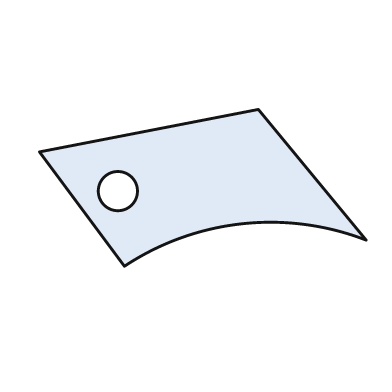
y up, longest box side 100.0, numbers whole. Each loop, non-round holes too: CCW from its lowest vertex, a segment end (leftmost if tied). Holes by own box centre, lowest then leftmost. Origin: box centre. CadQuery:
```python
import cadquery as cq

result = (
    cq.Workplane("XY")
    .moveTo(-24.0, -24.0)
    .threePointArc((12.0, -11.0), (50.0, -16.0))
    .lineTo(17.0, 24.0)
    .lineTo(-50.0, 11.0)
    .close()
    .moveTo(-26.0, -1.0)
    .circle(6.0)
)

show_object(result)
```